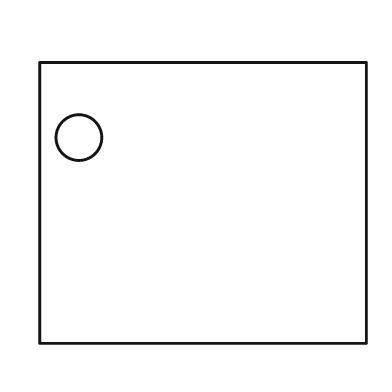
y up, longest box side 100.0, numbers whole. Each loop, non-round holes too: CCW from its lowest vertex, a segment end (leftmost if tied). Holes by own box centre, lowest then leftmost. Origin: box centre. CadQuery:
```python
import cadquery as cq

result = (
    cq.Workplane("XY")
    .moveTo(-50.0, -43.0)
    .lineTo(50.0, -43.0)
    .lineTo(50.0, 43.0)
    .lineTo(-50.0, 43.0)
    .close()
    .moveTo(-38.0, 20.0)
    .circle(7.0)
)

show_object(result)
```